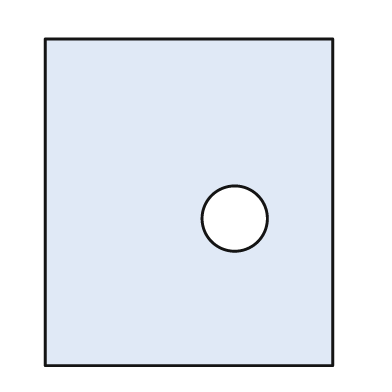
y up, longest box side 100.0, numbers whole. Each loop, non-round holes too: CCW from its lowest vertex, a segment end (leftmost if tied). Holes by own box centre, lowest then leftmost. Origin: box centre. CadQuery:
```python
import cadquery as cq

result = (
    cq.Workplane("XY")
    .moveTo(-44.0, -50.0)
    .lineTo(44.0, -50.0)
    .lineTo(44.0, 50.0)
    .lineTo(-44.0, 50.0)
    .close()
    .moveTo(14.0, -5.0)
    .circle(10.0)
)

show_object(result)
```